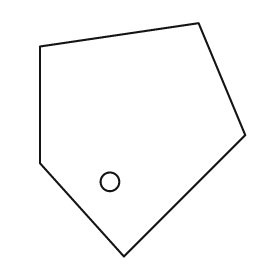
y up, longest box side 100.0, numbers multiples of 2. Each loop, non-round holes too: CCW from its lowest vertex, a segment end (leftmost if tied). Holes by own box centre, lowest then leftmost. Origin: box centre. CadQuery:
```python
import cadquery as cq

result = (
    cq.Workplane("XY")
    .moveTo(-8.0, -50.0)
    .lineTo(44.0, 2.0)
    .lineTo(24.0, 50.0)
    .lineTo(-44.0, 40.0)
    .lineTo(-44.0, -10.0)
    .close()
    .moveTo(-14.0, -18.0)
    .circle(4.0)
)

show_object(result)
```